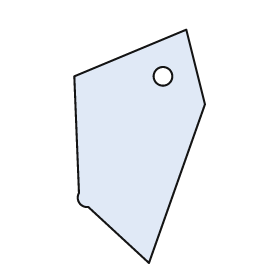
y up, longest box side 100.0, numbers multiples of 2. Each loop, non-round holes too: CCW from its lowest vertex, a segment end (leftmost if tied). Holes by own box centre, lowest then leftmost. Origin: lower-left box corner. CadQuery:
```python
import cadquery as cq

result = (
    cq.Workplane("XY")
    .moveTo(32.0, 0.0)
    .lineTo(56.0, 68.0)
    .lineTo(48.0, 100.0)
    .lineTo(0.0, 80.0)
    .lineTo(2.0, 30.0)
    .threePointArc((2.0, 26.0), (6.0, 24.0))
    .close()
    .moveTo(38.0, 80.0)
    .circle(4.0)
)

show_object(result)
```